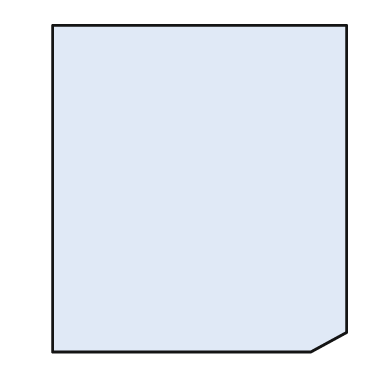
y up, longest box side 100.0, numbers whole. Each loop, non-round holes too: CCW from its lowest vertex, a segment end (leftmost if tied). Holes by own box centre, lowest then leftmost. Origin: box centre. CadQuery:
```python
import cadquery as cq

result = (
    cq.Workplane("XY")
    .moveTo(-45.0, -50.0)
    .lineTo(34.0, -50.0)
    .lineTo(45.0, -44.0)
    .lineTo(45.0, 50.0)
    .lineTo(-45.0, 50.0)
    .close()
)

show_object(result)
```